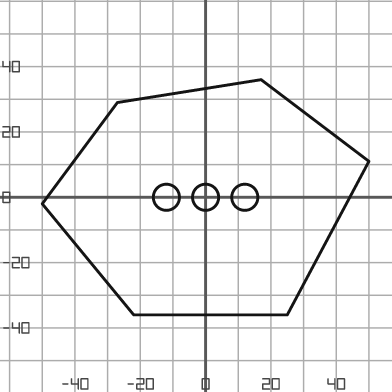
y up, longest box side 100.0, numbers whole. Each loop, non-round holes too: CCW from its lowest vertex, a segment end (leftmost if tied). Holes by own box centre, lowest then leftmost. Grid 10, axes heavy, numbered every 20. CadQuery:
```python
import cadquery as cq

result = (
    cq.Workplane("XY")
    .moveTo(-22.0, -36.0)
    .lineTo(25.0, -36.0)
    .lineTo(50.0, 11.0)
    .lineTo(17.0, 36.0)
    .lineTo(-27.0, 29.0)
    .lineTo(-50.0, -2.0)
    .close()
    .moveTo(-12.0, 0.0)
    .circle(4.0)
    .moveTo(0.0, 0.0)
    .circle(4.0)
    .moveTo(12.0, 0.0)
    .circle(4.0)
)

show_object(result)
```